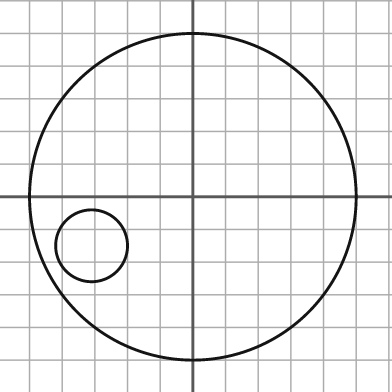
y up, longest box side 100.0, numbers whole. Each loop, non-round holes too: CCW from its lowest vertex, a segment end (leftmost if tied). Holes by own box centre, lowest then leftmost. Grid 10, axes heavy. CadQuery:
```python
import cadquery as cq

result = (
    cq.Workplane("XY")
    .moveTo(0.0, 0.0)
    .circle(50.0)
    .moveTo(-31.0, -15.0)
    .circle(11.0)
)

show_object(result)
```